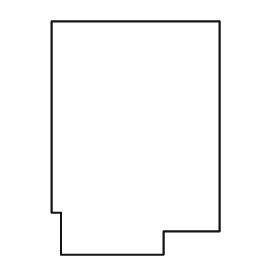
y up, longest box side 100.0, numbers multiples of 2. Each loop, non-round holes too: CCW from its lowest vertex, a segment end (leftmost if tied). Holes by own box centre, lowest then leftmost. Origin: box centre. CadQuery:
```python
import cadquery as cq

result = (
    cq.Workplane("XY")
    .moveTo(-32.0, -50.0)
    .lineTo(12.0, -50.0)
    .lineTo(12.0, -40.0)
    .lineTo(36.0, -40.0)
    .lineTo(36.0, 50.0)
    .lineTo(-36.0, 50.0)
    .lineTo(-36.0, -32.0)
    .lineTo(-32.0, -32.0)
    .close()
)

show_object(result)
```